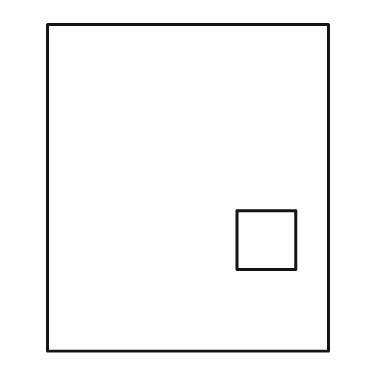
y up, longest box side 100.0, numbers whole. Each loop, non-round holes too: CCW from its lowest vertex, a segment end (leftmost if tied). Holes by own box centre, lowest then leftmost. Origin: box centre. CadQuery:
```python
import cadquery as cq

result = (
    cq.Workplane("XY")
    .moveTo(-43.0, -50.0)
    .lineTo(43.0, -50.0)
    .lineTo(43.0, 50.0)
    .lineTo(-43.0, 50.0)
    .close()
    .moveTo(15.0, -25.0)
    .lineTo(33.0, -25.0)
    .lineTo(33.0, -7.0)
    .lineTo(15.0, -7.0)
    .close()
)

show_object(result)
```